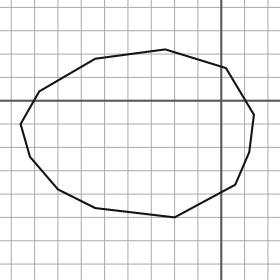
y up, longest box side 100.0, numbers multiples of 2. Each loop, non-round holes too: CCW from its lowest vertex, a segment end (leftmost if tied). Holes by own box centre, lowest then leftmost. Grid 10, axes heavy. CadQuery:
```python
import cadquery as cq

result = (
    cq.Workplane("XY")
    .moveTo(-20.0, -50.0)
    .lineTo(6.0, -36.0)
    .lineTo(12.0, -22.0)
    .lineTo(14.0, -6.0)
    .lineTo(2.0, 14.0)
    .lineTo(-24.0, 22.0)
    .lineTo(-54.0, 18.0)
    .lineTo(-78.0, 4.0)
    .lineTo(-86.0, -10.0)
    .lineTo(-82.0, -24.0)
    .lineTo(-70.0, -38.0)
    .lineTo(-54.0, -46.0)
    .close()
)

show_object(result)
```